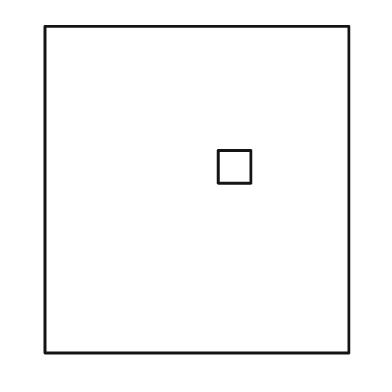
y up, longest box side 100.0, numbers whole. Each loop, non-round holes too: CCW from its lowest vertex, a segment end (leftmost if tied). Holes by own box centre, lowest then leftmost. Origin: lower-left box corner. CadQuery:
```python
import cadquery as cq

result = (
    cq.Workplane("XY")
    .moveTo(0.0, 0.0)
    .lineTo(93.0, 0.0)
    .lineTo(93.0, 100.0)
    .lineTo(0.0, 100.0)
    .close()
    .moveTo(53.0, 52.0)
    .lineTo(63.0, 52.0)
    .lineTo(63.0, 62.0)
    .lineTo(53.0, 62.0)
    .close()
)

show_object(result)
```